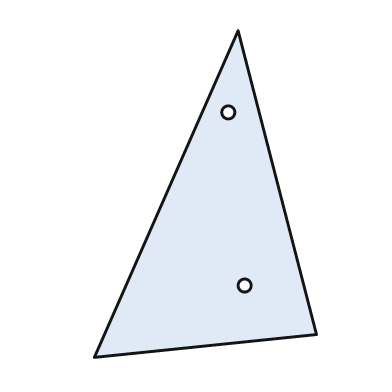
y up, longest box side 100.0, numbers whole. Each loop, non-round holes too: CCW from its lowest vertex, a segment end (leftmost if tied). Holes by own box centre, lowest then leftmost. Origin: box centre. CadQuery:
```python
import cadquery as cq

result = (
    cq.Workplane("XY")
    .moveTo(-34.0, -50.0)
    .lineTo(34.0, -43.0)
    .lineTo(10.0, 50.0)
    .close()
    .moveTo(12.0, -28.0)
    .circle(2.0)
    .moveTo(7.0, 25.0)
    .circle(2.0)
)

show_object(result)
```